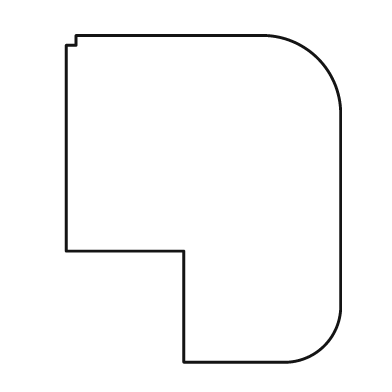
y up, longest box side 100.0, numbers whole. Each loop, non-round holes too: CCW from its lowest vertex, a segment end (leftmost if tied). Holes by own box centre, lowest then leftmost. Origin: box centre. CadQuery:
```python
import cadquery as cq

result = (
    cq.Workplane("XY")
    .moveTo(-6.0, -50.0)
    .lineTo(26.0, -50.0)
    .threePointArc((37.0, -45.0), (42.0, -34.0))
    .lineTo(42.0, 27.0)
    .threePointArc((35.0, 43.0), (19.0, 50.0))
    .lineTo(-39.0, 50.0)
    .lineTo(-39.0, 47.0)
    .lineTo(-42.0, 47.0)
    .lineTo(-42.0, -16.0)
    .lineTo(-6.0, -16.0)
    .close()
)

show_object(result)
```